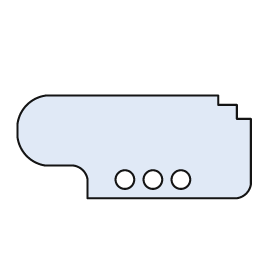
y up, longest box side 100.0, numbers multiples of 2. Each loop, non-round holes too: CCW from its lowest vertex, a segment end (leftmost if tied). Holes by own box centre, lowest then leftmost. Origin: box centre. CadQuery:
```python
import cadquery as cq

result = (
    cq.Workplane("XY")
    .moveTo(-20.0, -22.0)
    .lineTo(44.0, -22.0)
    .threePointArc((48.0, -20.0), (50.0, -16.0))
    .lineTo(50.0, 12.0)
    .lineTo(44.0, 12.0)
    .lineTo(44.0, 18.0)
    .lineTo(36.0, 18.0)
    .lineTo(36.0, 22.0)
    .lineTo(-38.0, 22.0)
    .threePointArc((-46.0, 18.0), (-50.0, 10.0))
    .lineTo(-50.0, 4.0)
    .threePointArc((-46.0, -4.0), (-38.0, -8.0))
    .lineTo(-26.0, -8.0)
    .threePointArc((-22.0, -10.0), (-20.0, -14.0))
    .close()
    .moveTo(-4.0, -14.0)
    .circle(4.0)
    .moveTo(8.0, -14.0)
    .circle(4.0)
    .moveTo(20.0, -14.0)
    .circle(4.0)
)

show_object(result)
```